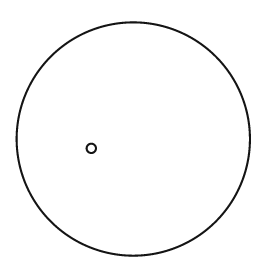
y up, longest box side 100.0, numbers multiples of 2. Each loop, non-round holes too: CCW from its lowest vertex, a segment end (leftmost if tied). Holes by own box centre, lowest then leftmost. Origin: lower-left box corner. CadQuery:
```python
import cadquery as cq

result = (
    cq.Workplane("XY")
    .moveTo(50.0, 50.0)
    .circle(50.0)
    .moveTo(32.0, 46.0)
    .circle(2.0)
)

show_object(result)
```